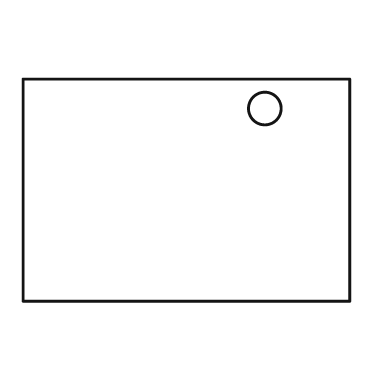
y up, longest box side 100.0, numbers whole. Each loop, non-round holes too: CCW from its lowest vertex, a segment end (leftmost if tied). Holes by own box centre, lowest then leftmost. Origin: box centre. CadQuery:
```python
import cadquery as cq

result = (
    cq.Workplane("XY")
    .moveTo(-50.0, -34.0)
    .lineTo(50.0, -34.0)
    .lineTo(50.0, 34.0)
    .lineTo(-50.0, 34.0)
    .close()
    .moveTo(24.0, 25.0)
    .circle(5.0)
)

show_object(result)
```